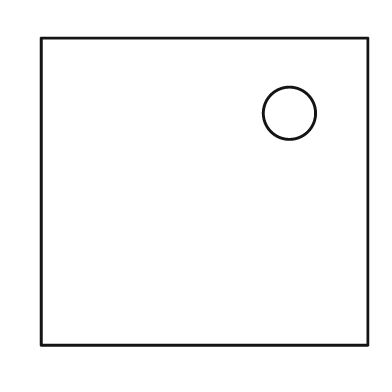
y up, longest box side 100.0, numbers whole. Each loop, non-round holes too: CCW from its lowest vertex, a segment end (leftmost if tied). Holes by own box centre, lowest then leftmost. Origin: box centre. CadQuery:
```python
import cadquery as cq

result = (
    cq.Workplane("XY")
    .moveTo(-50.0, -47.0)
    .lineTo(50.0, -47.0)
    .lineTo(50.0, 47.0)
    .lineTo(-50.0, 47.0)
    .close()
    .moveTo(26.0, 24.0)
    .circle(8.0)
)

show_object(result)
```